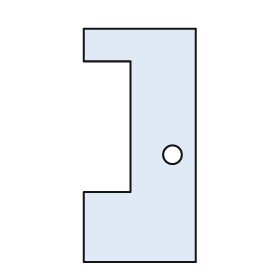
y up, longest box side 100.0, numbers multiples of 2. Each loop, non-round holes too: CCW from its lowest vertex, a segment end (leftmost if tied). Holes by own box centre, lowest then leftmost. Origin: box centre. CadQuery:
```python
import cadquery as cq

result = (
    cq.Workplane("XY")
    .moveTo(-24.0, -50.0)
    .lineTo(24.0, -50.0)
    .lineTo(24.0, 50.0)
    .lineTo(-24.0, 50.0)
    .lineTo(-24.0, 36.0)
    .lineTo(-4.0, 36.0)
    .lineTo(-4.0, -20.0)
    .lineTo(-24.0, -20.0)
    .close()
    .moveTo(14.0, -4.0)
    .circle(4.0)
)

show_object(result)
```